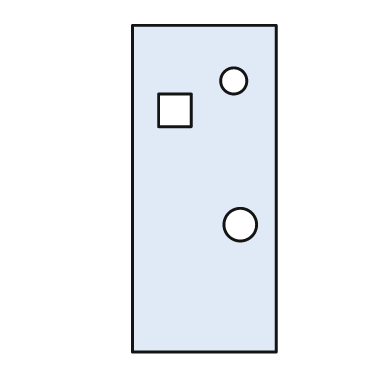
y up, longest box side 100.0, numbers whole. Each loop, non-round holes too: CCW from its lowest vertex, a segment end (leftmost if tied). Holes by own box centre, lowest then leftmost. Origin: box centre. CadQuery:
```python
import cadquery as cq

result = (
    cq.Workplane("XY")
    .moveTo(-22.0, -50.0)
    .lineTo(22.0, -50.0)
    .lineTo(22.0, 50.0)
    .lineTo(-22.0, 50.0)
    .close()
    .moveTo(11.0, -11.0)
    .circle(5.0)
    .moveTo(-14.0, 19.0)
    .lineTo(-4.0, 19.0)
    .lineTo(-4.0, 29.0)
    .lineTo(-14.0, 29.0)
    .close()
    .moveTo(9.0, 33.0)
    .circle(4.0)
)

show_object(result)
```